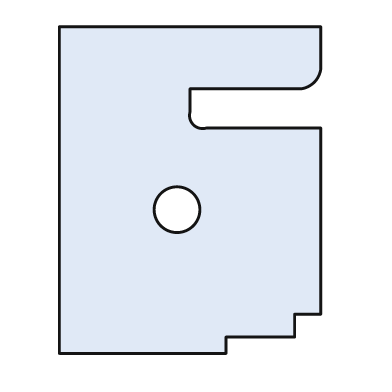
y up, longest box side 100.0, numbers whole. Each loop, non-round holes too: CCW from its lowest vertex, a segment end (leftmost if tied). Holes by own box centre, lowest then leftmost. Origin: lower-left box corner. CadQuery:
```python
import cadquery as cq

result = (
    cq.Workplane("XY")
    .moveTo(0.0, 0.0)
    .lineTo(51.0, 0.0)
    .lineTo(51.0, 5.0)
    .lineTo(72.0, 5.0)
    .lineTo(72.0, 12.0)
    .lineTo(80.0, 12.0)
    .lineTo(80.0, 69.0)
    .lineTo(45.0, 69.0)
    .threePointArc((41.0, 70.0), (40.0, 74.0))
    .lineTo(40.0, 81.0)
    .lineTo(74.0, 81.0)
    .threePointArc((78.0, 83.0), (80.0, 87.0))
    .lineTo(80.0, 100.0)
    .lineTo(0.0, 100.0)
    .close()
    .moveTo(36.0, 44.0)
    .circle(7.0)
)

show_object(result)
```